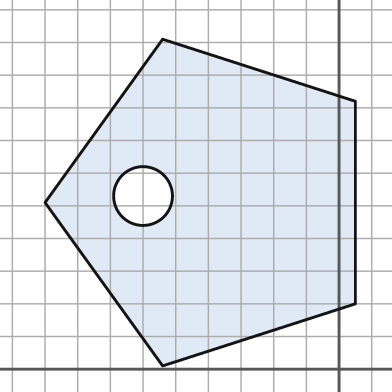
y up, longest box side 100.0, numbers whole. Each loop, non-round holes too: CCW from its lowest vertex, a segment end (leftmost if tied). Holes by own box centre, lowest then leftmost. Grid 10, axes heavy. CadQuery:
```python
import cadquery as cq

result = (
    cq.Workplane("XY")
    .moveTo(-54.0, 1.0)
    .lineTo(5.0, 20.0)
    .lineTo(5.0, 82.0)
    .lineTo(-54.0, 101.0)
    .lineTo(-90.0, 51.0)
    .close()
    .moveTo(-60.0, 53.0)
    .circle(9.0)
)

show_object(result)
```